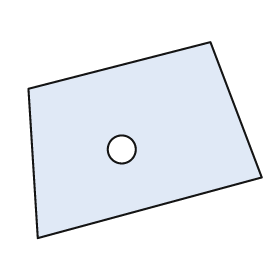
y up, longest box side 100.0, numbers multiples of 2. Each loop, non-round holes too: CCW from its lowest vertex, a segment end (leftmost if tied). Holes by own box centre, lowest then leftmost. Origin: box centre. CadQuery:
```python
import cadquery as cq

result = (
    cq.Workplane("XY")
    .moveTo(-46.0, -42.0)
    .lineTo(50.0, -16.0)
    .lineTo(28.0, 42.0)
    .lineTo(-50.0, 22.0)
    .close()
    .moveTo(-10.0, -4.0)
    .circle(6.0)
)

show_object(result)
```